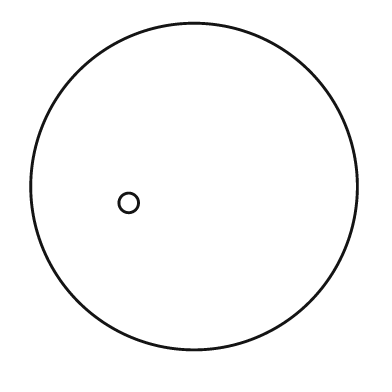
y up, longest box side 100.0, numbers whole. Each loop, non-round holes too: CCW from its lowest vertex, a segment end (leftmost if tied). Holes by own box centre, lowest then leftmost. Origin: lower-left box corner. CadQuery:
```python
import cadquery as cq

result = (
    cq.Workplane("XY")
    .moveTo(50.0, 50.0)
    .circle(50.0)
    .moveTo(30.0, 45.0)
    .circle(3.0)
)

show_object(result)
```